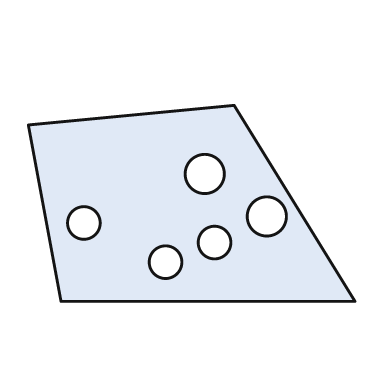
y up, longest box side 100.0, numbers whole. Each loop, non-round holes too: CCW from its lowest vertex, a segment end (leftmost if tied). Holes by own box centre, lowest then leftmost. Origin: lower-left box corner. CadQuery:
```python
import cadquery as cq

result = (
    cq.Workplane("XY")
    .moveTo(10.0, 0.0)
    .lineTo(100.0, 0.0)
    .lineTo(63.0, 60.0)
    .lineTo(0.0, 54.0)
    .close()
    .moveTo(42.0, 12.0)
    .circle(5.0)
    .moveTo(57.0, 18.0)
    .circle(5.0)
    .moveTo(17.0, 24.0)
    .circle(5.0)
    .moveTo(73.0, 26.0)
    .circle(6.0)
    .moveTo(54.0, 39.0)
    .circle(6.0)
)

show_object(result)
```